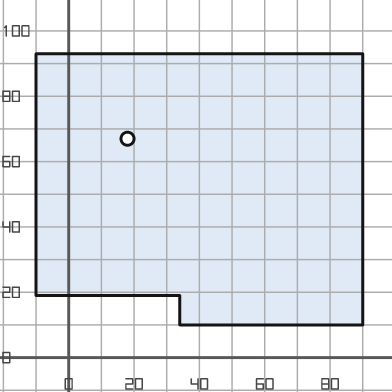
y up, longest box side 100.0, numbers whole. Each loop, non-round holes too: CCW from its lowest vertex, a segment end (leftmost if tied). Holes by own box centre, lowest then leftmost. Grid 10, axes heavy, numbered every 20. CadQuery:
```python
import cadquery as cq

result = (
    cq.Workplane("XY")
    .moveTo(34.0, 10.0)
    .lineTo(90.0, 10.0)
    .lineTo(90.0, 93.0)
    .lineTo(-10.0, 93.0)
    .lineTo(-10.0, 19.0)
    .lineTo(34.0, 19.0)
    .close()
    .moveTo(18.0, 67.0)
    .circle(2.0)
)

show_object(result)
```